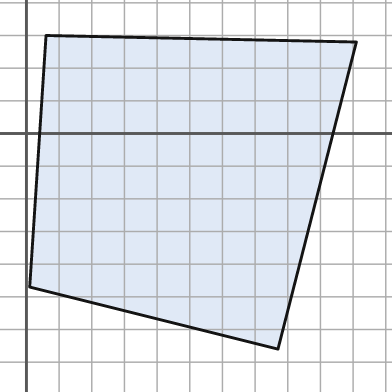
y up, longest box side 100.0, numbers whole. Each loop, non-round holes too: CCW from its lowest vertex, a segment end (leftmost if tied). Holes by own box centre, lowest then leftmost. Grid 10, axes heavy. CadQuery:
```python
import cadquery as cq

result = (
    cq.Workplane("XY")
    .moveTo(77.0, -66.0)
    .lineTo(101.0, 28.0)
    .lineTo(6.0, 30.0)
    .lineTo(1.0, -47.0)
    .close()
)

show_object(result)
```